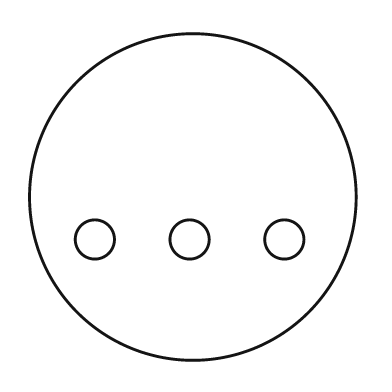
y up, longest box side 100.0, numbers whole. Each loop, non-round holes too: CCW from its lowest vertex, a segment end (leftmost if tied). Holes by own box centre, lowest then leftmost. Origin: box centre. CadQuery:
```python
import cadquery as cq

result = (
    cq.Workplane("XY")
    .moveTo(0.0, 0.0)
    .circle(50.0)
    .moveTo(-30.0, -13.0)
    .circle(6.0)
    .moveTo(-1.0, -13.0)
    .circle(6.0)
    .moveTo(28.0, -13.0)
    .circle(6.0)
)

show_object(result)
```